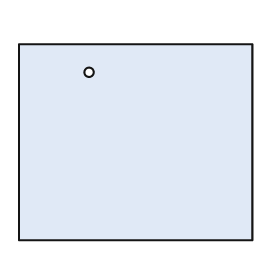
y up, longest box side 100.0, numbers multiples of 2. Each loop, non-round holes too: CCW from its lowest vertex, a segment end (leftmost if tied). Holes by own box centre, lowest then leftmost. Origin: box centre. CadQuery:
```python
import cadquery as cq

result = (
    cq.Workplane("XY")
    .moveTo(-50.0, -42.0)
    .lineTo(50.0, -42.0)
    .lineTo(50.0, 42.0)
    .lineTo(-50.0, 42.0)
    .close()
    .moveTo(-20.0, 30.0)
    .circle(2.0)
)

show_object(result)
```